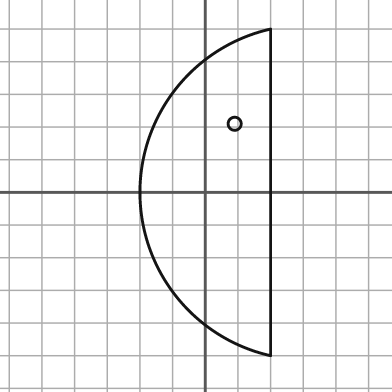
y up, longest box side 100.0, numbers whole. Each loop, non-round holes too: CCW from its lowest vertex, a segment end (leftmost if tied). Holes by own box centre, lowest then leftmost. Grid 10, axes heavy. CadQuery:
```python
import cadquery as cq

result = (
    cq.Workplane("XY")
    .moveTo(20.0, -50.0)
    .lineTo(20.0, 50.0)
    .threePointArc((-20.0, 0.0), (20.0, -50.0))
    .close()
    .moveTo(9.0, 21.0)
    .circle(2.0)
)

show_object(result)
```